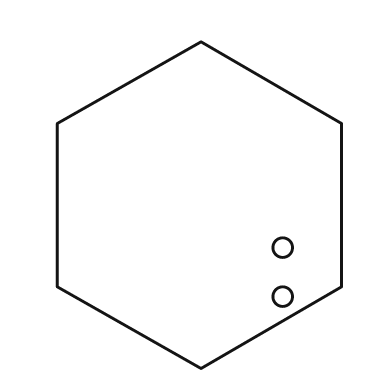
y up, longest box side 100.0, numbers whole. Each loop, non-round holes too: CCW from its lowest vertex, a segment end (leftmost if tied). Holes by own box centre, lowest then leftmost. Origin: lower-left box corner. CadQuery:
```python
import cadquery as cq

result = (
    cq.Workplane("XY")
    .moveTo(44.0, 0.0)
    .lineTo(87.0, 25.0)
    .lineTo(87.0, 75.0)
    .lineTo(44.0, 100.0)
    .lineTo(0.0, 75.0)
    .lineTo(0.0, 25.0)
    .close()
    .moveTo(69.0, 22.0)
    .circle(3.0)
    .moveTo(69.0, 37.0)
    .circle(3.0)
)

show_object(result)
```